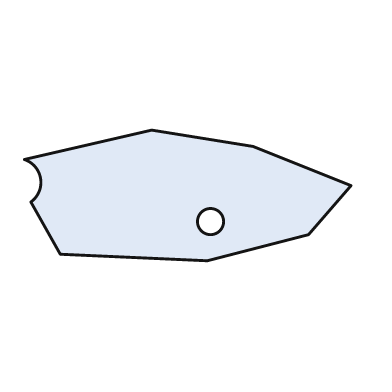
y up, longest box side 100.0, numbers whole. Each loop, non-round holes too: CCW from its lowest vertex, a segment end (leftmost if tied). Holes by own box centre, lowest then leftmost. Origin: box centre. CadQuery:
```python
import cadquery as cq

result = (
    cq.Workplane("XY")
    .moveTo(6.0, -20.0)
    .lineTo(37.0, -12.0)
    .lineTo(50.0, 3.0)
    .lineTo(20.0, 15.0)
    .lineTo(-11.0, 20.0)
    .lineTo(-50.0, 11.0)
    .threePointArc((-45.0, 5.0), (-48.0, -2.0))
    .lineTo(-39.0, -18.0)
    .close()
    .moveTo(7.0, -8.0)
    .circle(4.0)
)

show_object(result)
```